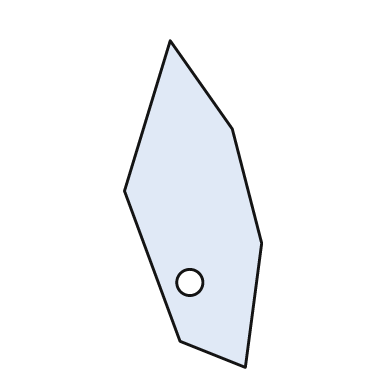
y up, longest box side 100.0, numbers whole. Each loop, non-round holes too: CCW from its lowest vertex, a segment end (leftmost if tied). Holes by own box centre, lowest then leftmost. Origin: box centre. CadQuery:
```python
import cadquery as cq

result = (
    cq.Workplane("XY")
    .moveTo(16.0, -50.0)
    .lineTo(21.0, -12.0)
    .lineTo(12.0, 23.0)
    .lineTo(-7.0, 50.0)
    .lineTo(-21.0, 4.0)
    .lineTo(-4.0, -42.0)
    .close()
    .moveTo(-1.0, -24.0)
    .circle(4.0)
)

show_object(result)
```